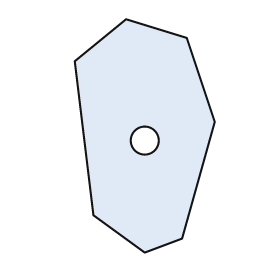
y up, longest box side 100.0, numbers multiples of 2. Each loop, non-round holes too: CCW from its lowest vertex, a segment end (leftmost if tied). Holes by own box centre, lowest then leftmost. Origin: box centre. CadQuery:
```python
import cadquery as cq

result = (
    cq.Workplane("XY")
    .moveTo(0.0, -50.0)
    .lineTo(16.0, -44.0)
    .lineTo(30.0, 6.0)
    .lineTo(18.0, 42.0)
    .lineTo(-8.0, 50.0)
    .lineTo(-30.0, 32.0)
    .lineTo(-22.0, -34.0)
    .close()
    .moveTo(0.0, -2.0)
    .circle(6.0)
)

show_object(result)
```